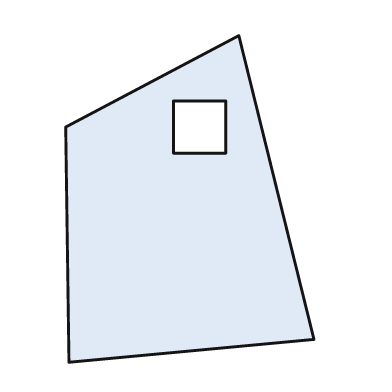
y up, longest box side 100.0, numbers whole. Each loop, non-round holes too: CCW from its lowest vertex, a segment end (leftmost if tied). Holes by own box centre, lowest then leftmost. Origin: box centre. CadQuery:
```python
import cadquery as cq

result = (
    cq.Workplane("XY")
    .moveTo(-37.0, -50.0)
    .lineTo(38.0, -43.0)
    .lineTo(15.0, 50.0)
    .lineTo(-38.0, 22.0)
    .close()
    .moveTo(-5.0, 14.0)
    .lineTo(11.0, 14.0)
    .lineTo(11.0, 30.0)
    .lineTo(-5.0, 30.0)
    .close()
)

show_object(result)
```